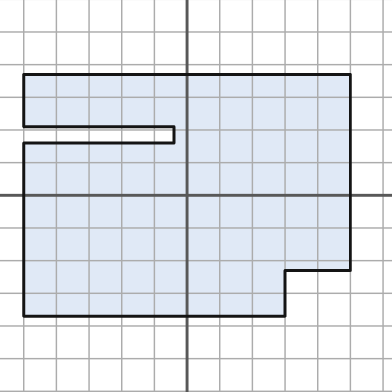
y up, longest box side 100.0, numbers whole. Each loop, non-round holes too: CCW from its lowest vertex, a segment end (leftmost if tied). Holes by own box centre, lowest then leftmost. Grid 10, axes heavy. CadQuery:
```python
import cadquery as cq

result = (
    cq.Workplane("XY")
    .moveTo(-50.0, -37.0)
    .lineTo(30.0, -37.0)
    .lineTo(30.0, -23.0)
    .lineTo(50.0, -23.0)
    .lineTo(50.0, 37.0)
    .lineTo(-50.0, 37.0)
    .lineTo(-50.0, 21.0)
    .lineTo(-4.0, 21.0)
    .lineTo(-4.0, 16.0)
    .lineTo(-50.0, 16.0)
    .close()
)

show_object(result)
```